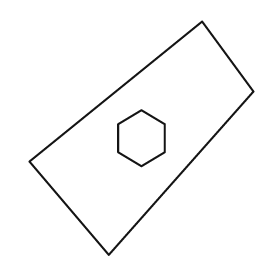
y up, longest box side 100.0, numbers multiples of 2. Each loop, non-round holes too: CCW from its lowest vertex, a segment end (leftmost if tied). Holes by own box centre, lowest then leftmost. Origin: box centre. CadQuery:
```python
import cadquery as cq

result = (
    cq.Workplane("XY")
    .moveTo(-14.0, -50.0)
    .lineTo(48.0, 20.0)
    .lineTo(26.0, 50.0)
    .lineTo(-48.0, -10.0)
    .close()
    .moveTo(0.0, -12.0)
    .lineTo(10.0, -6.0)
    .lineTo(10.0, 6.0)
    .lineTo(0.0, 12.0)
    .lineTo(-10.0, 6.0)
    .lineTo(-10.0, -6.0)
    .close()
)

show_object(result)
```